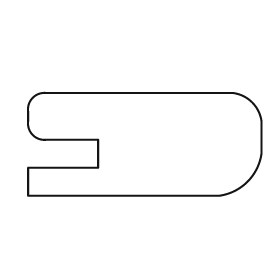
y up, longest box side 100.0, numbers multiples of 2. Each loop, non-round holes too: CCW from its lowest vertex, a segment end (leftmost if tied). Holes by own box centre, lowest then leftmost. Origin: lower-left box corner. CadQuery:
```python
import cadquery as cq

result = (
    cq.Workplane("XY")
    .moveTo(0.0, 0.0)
    .lineTo(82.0, 0.0)
    .threePointArc((94.0, 6.0), (100.0, 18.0))
    .lineTo(100.0, 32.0)
    .threePointArc((96.0, 40.0), (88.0, 44.0))
    .lineTo(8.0, 44.0)
    .threePointArc((2.0, 42.0), (0.0, 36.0))
    .lineTo(0.0, 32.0)
    .threePointArc((2.0, 26.0), (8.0, 24.0))
    .lineTo(30.0, 24.0)
    .lineTo(30.0, 12.0)
    .lineTo(0.0, 12.0)
    .close()
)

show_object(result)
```